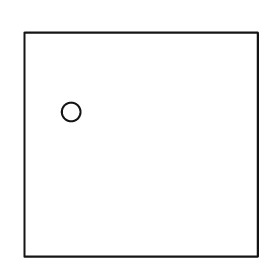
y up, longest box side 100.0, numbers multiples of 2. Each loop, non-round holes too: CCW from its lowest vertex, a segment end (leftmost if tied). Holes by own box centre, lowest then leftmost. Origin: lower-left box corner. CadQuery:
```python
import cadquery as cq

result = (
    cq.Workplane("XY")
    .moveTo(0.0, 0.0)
    .lineTo(100.0, 0.0)
    .lineTo(100.0, 96.0)
    .lineTo(0.0, 96.0)
    .close()
    .moveTo(20.0, 62.0)
    .circle(4.0)
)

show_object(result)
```